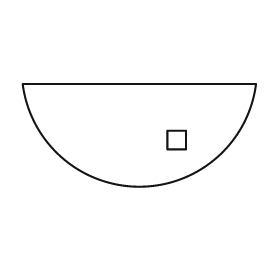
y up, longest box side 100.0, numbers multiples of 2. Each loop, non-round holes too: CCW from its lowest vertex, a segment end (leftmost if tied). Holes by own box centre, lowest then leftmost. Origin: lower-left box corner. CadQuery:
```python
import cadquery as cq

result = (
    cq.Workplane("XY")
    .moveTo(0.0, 44.0)
    .threePointArc((50.0, 0.0), (100.0, 44.0))
    .close()
    .moveTo(62.0, 16.0)
    .lineTo(70.0, 16.0)
    .lineTo(70.0, 24.0)
    .lineTo(62.0, 24.0)
    .close()
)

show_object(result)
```